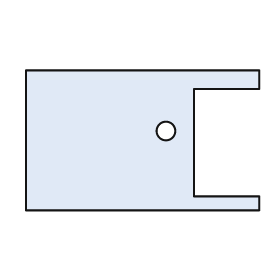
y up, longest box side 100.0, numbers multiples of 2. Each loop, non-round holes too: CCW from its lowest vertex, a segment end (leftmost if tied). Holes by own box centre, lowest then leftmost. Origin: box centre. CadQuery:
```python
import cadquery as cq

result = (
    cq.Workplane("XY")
    .moveTo(-50.0, -30.0)
    .lineTo(50.0, -30.0)
    .lineTo(50.0, -24.0)
    .lineTo(22.0, -24.0)
    .lineTo(22.0, 22.0)
    .lineTo(50.0, 22.0)
    .lineTo(50.0, 30.0)
    .lineTo(-50.0, 30.0)
    .close()
    .moveTo(10.0, 4.0)
    .circle(4.0)
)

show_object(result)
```